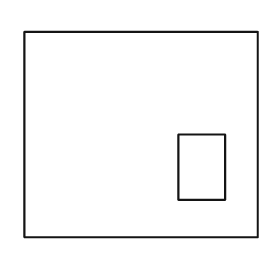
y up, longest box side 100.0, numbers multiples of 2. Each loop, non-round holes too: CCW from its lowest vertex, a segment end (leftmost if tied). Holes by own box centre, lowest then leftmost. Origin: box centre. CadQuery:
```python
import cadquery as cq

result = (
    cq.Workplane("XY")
    .moveTo(-50.0, -44.0)
    .lineTo(50.0, -44.0)
    .lineTo(50.0, 44.0)
    .lineTo(-50.0, 44.0)
    .close()
    .moveTo(16.0, -28.0)
    .lineTo(36.0, -28.0)
    .lineTo(36.0, 0.0)
    .lineTo(16.0, 0.0)
    .close()
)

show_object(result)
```